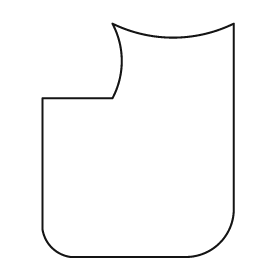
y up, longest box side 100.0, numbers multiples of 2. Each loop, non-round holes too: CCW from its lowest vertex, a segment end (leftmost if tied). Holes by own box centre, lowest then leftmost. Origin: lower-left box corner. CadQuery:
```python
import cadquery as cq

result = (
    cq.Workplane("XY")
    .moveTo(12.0, 0.0)
    .lineTo(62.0, 0.0)
    .threePointArc((76.0, 6.0), (82.0, 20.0))
    .lineTo(82.0, 100.0)
    .threePointArc((56.0, 94.0), (30.0, 100.0))
    .threePointArc((34.0, 84.0), (30.0, 68.0))
    .lineTo(0.0, 68.0)
    .lineTo(0.0, 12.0)
    .threePointArc((4.0, 4.0), (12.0, 0.0))
    .close()
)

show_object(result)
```